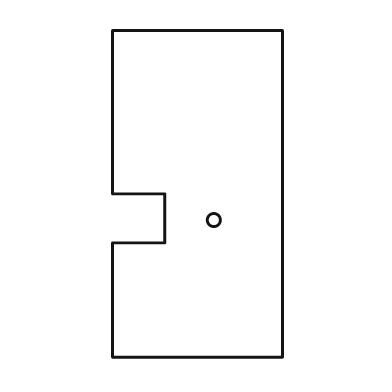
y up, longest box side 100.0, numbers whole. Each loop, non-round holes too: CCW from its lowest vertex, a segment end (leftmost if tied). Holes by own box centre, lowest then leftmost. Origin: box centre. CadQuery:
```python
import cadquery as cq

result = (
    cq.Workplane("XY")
    .moveTo(-26.0, -50.0)
    .lineTo(26.0, -50.0)
    .lineTo(26.0, 50.0)
    .lineTo(-26.0, 50.0)
    .lineTo(-26.0, 0.0)
    .lineTo(-10.0, 0.0)
    .lineTo(-10.0, -15.0)
    .lineTo(-26.0, -15.0)
    .close()
    .moveTo(5.0, -8.0)
    .circle(2.0)
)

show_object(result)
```